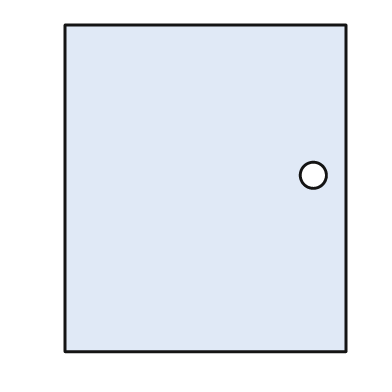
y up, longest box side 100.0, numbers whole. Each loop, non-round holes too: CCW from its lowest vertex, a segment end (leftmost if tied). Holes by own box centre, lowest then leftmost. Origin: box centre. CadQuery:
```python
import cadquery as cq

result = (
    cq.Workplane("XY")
    .moveTo(-43.0, -50.0)
    .lineTo(43.0, -50.0)
    .lineTo(43.0, 50.0)
    .lineTo(-43.0, 50.0)
    .close()
    .moveTo(33.0, 4.0)
    .circle(4.0)
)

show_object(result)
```